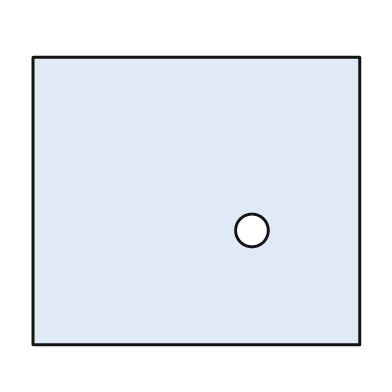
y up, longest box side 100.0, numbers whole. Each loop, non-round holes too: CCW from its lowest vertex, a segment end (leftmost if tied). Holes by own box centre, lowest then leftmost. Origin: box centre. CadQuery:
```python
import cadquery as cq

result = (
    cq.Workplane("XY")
    .moveTo(-50.0, -44.0)
    .lineTo(50.0, -44.0)
    .lineTo(50.0, 44.0)
    .lineTo(-50.0, 44.0)
    .close()
    .moveTo(17.0, -9.0)
    .circle(5.0)
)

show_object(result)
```